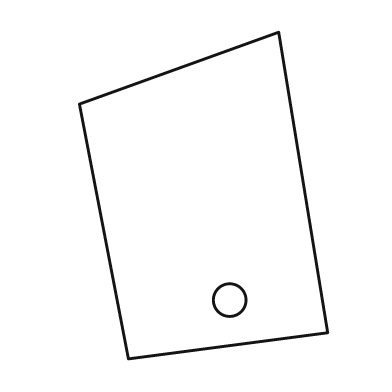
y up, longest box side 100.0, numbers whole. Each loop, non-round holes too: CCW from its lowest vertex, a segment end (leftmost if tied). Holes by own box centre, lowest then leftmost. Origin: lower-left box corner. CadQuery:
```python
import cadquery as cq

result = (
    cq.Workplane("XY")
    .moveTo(15.0, 0.0)
    .lineTo(76.0, 8.0)
    .lineTo(61.0, 100.0)
    .lineTo(0.0, 78.0)
    .close()
    .moveTo(46.0, 18.0)
    .circle(5.0)
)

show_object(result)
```